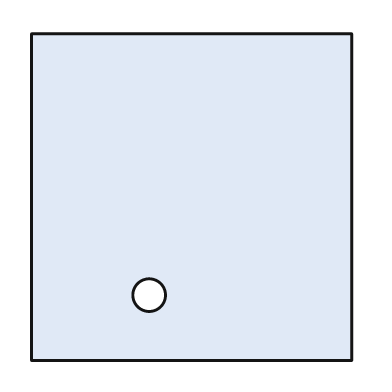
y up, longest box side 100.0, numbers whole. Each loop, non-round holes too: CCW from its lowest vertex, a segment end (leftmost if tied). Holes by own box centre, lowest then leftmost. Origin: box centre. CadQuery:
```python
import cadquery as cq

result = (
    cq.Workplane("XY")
    .moveTo(-49.0, -50.0)
    .lineTo(49.0, -50.0)
    .lineTo(49.0, 50.0)
    .lineTo(-49.0, 50.0)
    .close()
    .moveTo(-13.0, -30.0)
    .circle(5.0)
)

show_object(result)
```